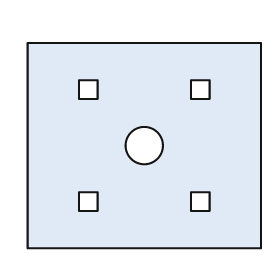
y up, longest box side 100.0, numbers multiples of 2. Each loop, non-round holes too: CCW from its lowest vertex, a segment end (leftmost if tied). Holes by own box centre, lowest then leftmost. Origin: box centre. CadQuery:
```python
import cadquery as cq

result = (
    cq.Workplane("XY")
    .moveTo(-50.0, -44.0)
    .lineTo(50.0, -44.0)
    .lineTo(50.0, 44.0)
    .lineTo(-50.0, 44.0)
    .close()
    .moveTo(-28.0, -28.0)
    .lineTo(-20.0, -28.0)
    .lineTo(-20.0, -20.0)
    .lineTo(-28.0, -20.0)
    .close()
    .moveTo(20.0, -28.0)
    .lineTo(28.0, -28.0)
    .lineTo(28.0, -20.0)
    .lineTo(20.0, -20.0)
    .close()
    .moveTo(0.0, 0.0)
    .circle(8.0)
    .moveTo(-28.0, 20.0)
    .lineTo(-20.0, 20.0)
    .lineTo(-20.0, 28.0)
    .lineTo(-28.0, 28.0)
    .close()
    .moveTo(20.0, 20.0)
    .lineTo(28.0, 20.0)
    .lineTo(28.0, 28.0)
    .lineTo(20.0, 28.0)
    .close()
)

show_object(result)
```